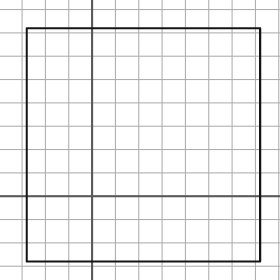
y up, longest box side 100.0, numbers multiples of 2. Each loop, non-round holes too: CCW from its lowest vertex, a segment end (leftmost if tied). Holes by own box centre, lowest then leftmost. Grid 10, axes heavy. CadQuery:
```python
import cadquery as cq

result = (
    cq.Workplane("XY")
    .moveTo(-28.0, -28.0)
    .lineTo(72.0, -28.0)
    .lineTo(72.0, 72.0)
    .lineTo(-28.0, 72.0)
    .close()
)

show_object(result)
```